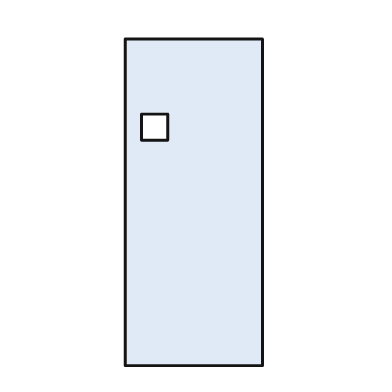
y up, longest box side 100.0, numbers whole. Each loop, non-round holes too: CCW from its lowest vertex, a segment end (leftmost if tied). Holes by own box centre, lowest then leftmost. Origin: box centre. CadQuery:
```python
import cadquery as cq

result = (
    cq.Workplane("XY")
    .moveTo(-21.0, -50.0)
    .lineTo(21.0, -50.0)
    .lineTo(21.0, 50.0)
    .lineTo(-21.0, 50.0)
    .close()
    .moveTo(-16.0, 19.0)
    .lineTo(-8.0, 19.0)
    .lineTo(-8.0, 27.0)
    .lineTo(-16.0, 27.0)
    .close()
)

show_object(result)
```